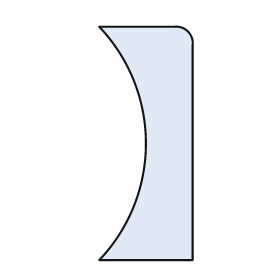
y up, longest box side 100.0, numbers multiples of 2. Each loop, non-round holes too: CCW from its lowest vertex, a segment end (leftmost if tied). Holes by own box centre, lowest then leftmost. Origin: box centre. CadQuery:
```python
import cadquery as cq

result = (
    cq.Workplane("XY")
    .moveTo(-20.0, -50.0)
    .lineTo(20.0, -50.0)
    .lineTo(20.0, 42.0)
    .threePointArc((18.0, 48.0), (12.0, 50.0))
    .lineTo(-20.0, 50.0)
    .threePointArc((0.0, 0.0), (-20.0, -50.0))
    .close()
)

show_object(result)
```